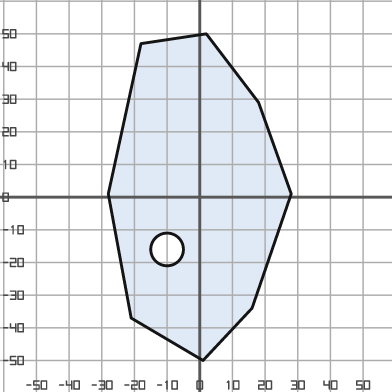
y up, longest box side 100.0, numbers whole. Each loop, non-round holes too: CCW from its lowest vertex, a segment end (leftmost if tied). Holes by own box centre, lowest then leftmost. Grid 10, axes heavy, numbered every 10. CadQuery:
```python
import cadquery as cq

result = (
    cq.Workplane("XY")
    .moveTo(1.0, -50.0)
    .lineTo(16.0, -34.0)
    .lineTo(28.0, 1.0)
    .lineTo(18.0, 29.0)
    .lineTo(2.0, 50.0)
    .lineTo(-18.0, 47.0)
    .lineTo(-28.0, 1.0)
    .lineTo(-21.0, -37.0)
    .close()
    .moveTo(-10.0, -16.0)
    .circle(5.0)
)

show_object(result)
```